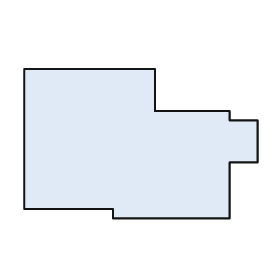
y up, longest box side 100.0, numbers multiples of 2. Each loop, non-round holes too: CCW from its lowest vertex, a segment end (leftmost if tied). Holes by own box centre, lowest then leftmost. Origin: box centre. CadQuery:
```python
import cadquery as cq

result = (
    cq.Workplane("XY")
    .moveTo(-12.0, -32.0)
    .lineTo(38.0, -32.0)
    .lineTo(38.0, -8.0)
    .lineTo(50.0, -8.0)
    .lineTo(50.0, 10.0)
    .lineTo(38.0, 10.0)
    .lineTo(38.0, 14.0)
    .lineTo(6.0, 14.0)
    .lineTo(6.0, 32.0)
    .lineTo(-50.0, 32.0)
    .lineTo(-50.0, -28.0)
    .lineTo(-12.0, -28.0)
    .close()
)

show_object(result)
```